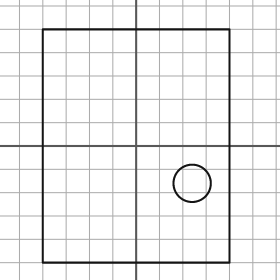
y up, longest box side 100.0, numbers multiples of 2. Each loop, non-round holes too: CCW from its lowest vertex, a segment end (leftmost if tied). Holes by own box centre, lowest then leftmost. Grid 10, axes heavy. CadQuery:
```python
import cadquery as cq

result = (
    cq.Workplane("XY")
    .moveTo(-40.0, -50.0)
    .lineTo(40.0, -50.0)
    .lineTo(40.0, 50.0)
    .lineTo(-40.0, 50.0)
    .close()
    .moveTo(24.0, -16.0)
    .circle(8.0)
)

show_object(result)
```